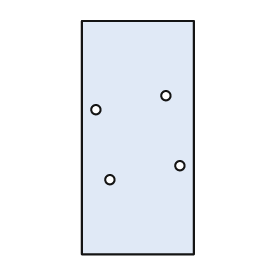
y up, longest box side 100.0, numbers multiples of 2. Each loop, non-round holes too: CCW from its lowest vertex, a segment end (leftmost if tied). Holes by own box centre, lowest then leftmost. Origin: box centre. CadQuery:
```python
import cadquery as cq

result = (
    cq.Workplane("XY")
    .moveTo(-24.0, -50.0)
    .lineTo(24.0, -50.0)
    .lineTo(24.0, 50.0)
    .lineTo(-24.0, 50.0)
    .close()
    .moveTo(-12.0, -18.0)
    .circle(2.0)
    .moveTo(18.0, -12.0)
    .circle(2.0)
    .moveTo(-18.0, 12.0)
    .circle(2.0)
    .moveTo(12.0, 18.0)
    .circle(2.0)
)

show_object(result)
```